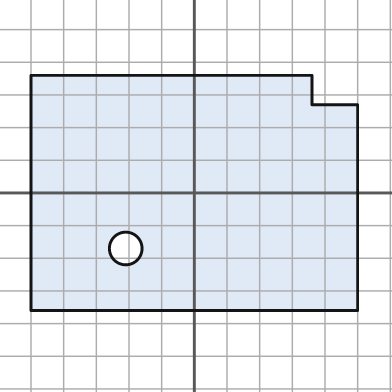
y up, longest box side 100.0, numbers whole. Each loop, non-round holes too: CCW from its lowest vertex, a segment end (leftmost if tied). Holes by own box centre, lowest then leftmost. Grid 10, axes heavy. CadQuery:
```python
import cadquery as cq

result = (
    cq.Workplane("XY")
    .moveTo(-50.0, -36.0)
    .lineTo(50.0, -36.0)
    .lineTo(50.0, 27.0)
    .lineTo(36.0, 27.0)
    .lineTo(36.0, 36.0)
    .lineTo(-50.0, 36.0)
    .close()
    .moveTo(-21.0, -17.0)
    .circle(5.0)
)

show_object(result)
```